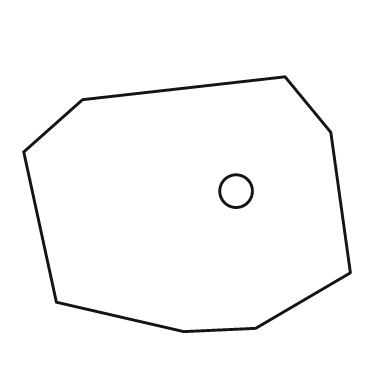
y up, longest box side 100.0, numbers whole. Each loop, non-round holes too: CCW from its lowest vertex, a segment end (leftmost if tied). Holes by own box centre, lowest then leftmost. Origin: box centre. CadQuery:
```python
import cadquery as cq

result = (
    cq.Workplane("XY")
    .moveTo(-1.0, -39.0)
    .lineTo(21.0, -38.0)
    .lineTo(50.0, -21.0)
    .lineTo(44.0, 22.0)
    .lineTo(30.0, 39.0)
    .lineTo(-32.0, 32.0)
    .lineTo(-50.0, 16.0)
    .lineTo(-40.0, -30.0)
    .close()
    .moveTo(15.0, 4.0)
    .circle(5.0)
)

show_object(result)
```